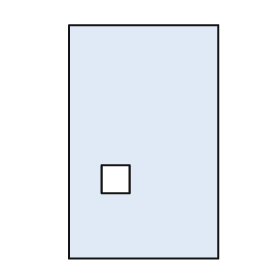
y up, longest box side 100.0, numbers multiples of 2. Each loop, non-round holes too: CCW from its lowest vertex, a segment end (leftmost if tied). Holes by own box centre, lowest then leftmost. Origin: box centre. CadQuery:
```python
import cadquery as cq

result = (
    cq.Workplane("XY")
    .moveTo(-32.0, -50.0)
    .lineTo(32.0, -50.0)
    .lineTo(32.0, 50.0)
    .lineTo(-32.0, 50.0)
    .close()
    .moveTo(-18.0, -22.0)
    .lineTo(-6.0, -22.0)
    .lineTo(-6.0, -10.0)
    .lineTo(-18.0, -10.0)
    .close()
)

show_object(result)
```